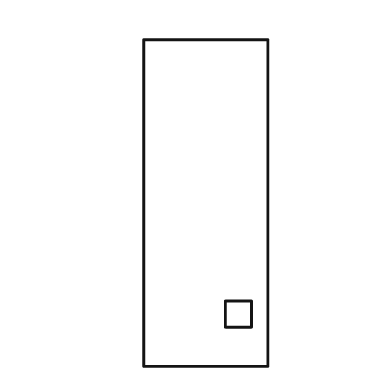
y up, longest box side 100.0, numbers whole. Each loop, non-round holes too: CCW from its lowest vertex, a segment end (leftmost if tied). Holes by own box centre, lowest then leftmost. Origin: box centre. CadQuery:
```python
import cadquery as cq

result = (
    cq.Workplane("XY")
    .moveTo(-19.0, -50.0)
    .lineTo(19.0, -50.0)
    .lineTo(19.0, 50.0)
    .lineTo(-19.0, 50.0)
    .close()
    .moveTo(6.0, -38.0)
    .lineTo(14.0, -38.0)
    .lineTo(14.0, -30.0)
    .lineTo(6.0, -30.0)
    .close()
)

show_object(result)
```